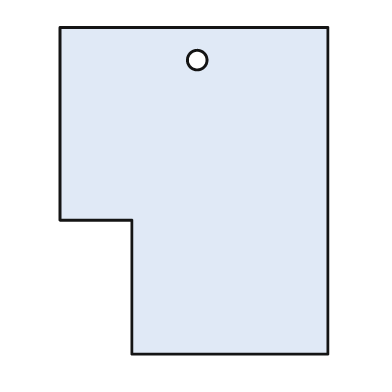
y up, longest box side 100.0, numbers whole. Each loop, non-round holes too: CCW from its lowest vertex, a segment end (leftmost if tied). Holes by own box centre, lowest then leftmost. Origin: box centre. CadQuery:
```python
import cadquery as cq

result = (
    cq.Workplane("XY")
    .moveTo(-19.0, -50.0)
    .lineTo(41.0, -50.0)
    .lineTo(41.0, 50.0)
    .lineTo(-41.0, 50.0)
    .lineTo(-41.0, -9.0)
    .lineTo(-19.0, -9.0)
    .close()
    .moveTo(1.0, 40.0)
    .circle(3.0)
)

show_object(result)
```